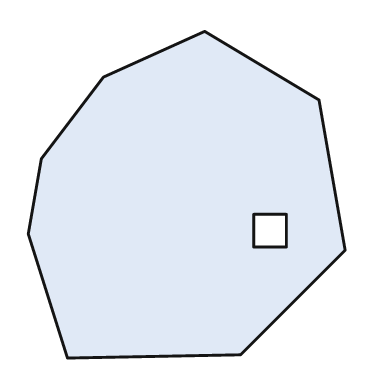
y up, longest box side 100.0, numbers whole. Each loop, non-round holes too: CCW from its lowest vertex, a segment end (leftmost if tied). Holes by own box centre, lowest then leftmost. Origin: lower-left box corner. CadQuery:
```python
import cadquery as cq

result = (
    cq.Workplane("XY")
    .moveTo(12.0, 0.0)
    .lineTo(65.0, 1.0)
    .lineTo(97.0, 33.0)
    .lineTo(89.0, 79.0)
    .lineTo(54.0, 100.0)
    .lineTo(23.0, 86.0)
    .lineTo(4.0, 61.0)
    .lineTo(0.0, 38.0)
    .close()
    .moveTo(69.0, 34.0)
    .lineTo(79.0, 34.0)
    .lineTo(79.0, 44.0)
    .lineTo(69.0, 44.0)
    .close()
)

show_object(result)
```